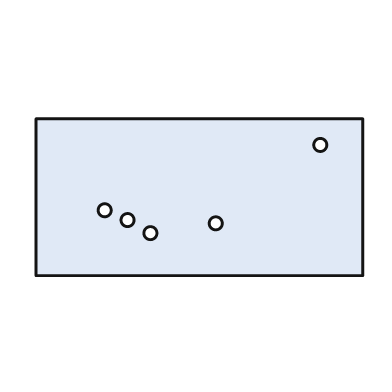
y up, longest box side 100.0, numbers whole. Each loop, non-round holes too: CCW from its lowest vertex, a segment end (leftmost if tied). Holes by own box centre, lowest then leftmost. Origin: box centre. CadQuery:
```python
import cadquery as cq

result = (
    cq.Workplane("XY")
    .moveTo(-50.0, -24.0)
    .lineTo(50.0, -24.0)
    .lineTo(50.0, 24.0)
    .lineTo(-50.0, 24.0)
    .close()
    .moveTo(-15.0, -11.0)
    .circle(2.0)
    .moveTo(5.0, -8.0)
    .circle(2.0)
    .moveTo(-22.0, -7.0)
    .circle(2.0)
    .moveTo(-29.0, -4.0)
    .circle(2.0)
    .moveTo(37.0, 16.0)
    .circle(2.0)
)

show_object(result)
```